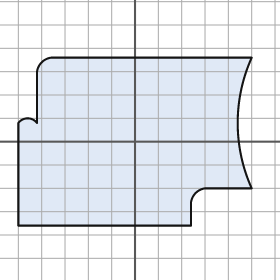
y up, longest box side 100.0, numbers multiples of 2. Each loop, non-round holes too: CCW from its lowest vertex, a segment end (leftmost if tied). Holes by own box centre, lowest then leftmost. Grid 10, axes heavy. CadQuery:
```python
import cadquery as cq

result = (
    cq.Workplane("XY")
    .moveTo(-50.0, -36.0)
    .lineTo(24.0, -36.0)
    .lineTo(24.0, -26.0)
    .threePointArc((26.0, -22.0), (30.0, -20.0))
    .lineTo(50.0, -20.0)
    .threePointArc((44.0, 8.0), (50.0, 36.0))
    .lineTo(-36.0, 36.0)
    .threePointArc((-40.0, 34.0), (-42.0, 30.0))
    .lineTo(-42.0, 8.0)
    .threePointArc((-46.0, 10.0), (-50.0, 8.0))
    .close()
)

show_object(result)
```